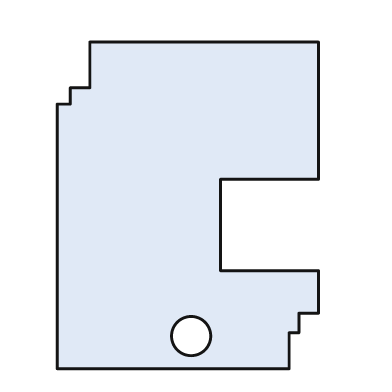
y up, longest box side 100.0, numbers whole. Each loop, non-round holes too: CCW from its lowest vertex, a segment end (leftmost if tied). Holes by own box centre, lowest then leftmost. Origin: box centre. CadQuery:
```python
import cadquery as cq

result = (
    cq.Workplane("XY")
    .moveTo(-40.0, -50.0)
    .lineTo(31.0, -50.0)
    .lineTo(31.0, -39.0)
    .lineTo(34.0, -39.0)
    .lineTo(34.0, -33.0)
    .lineTo(40.0, -33.0)
    .lineTo(40.0, -20.0)
    .lineTo(10.0, -20.0)
    .lineTo(10.0, 8.0)
    .lineTo(40.0, 8.0)
    .lineTo(40.0, 50.0)
    .lineTo(-30.0, 50.0)
    .lineTo(-30.0, 36.0)
    .lineTo(-36.0, 36.0)
    .lineTo(-36.0, 31.0)
    .lineTo(-40.0, 31.0)
    .close()
    .moveTo(1.0, -40.0)
    .circle(6.0)
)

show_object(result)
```